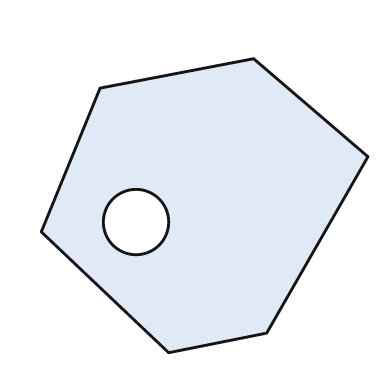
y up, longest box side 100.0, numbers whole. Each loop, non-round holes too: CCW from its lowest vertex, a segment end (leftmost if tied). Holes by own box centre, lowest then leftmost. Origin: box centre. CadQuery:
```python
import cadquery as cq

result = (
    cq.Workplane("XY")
    .moveTo(-11.0, -45.0)
    .lineTo(19.0, -39.0)
    .lineTo(50.0, 15.0)
    .lineTo(15.0, 45.0)
    .lineTo(-32.0, 36.0)
    .lineTo(-50.0, -8.0)
    .close()
    .moveTo(-21.0, -5.0)
    .circle(10.0)
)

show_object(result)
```